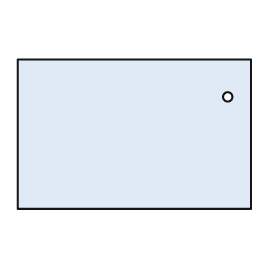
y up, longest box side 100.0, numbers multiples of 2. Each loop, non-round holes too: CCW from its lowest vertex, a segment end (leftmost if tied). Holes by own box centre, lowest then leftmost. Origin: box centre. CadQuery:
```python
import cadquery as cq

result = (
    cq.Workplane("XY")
    .moveTo(-50.0, -32.0)
    .lineTo(50.0, -32.0)
    .lineTo(50.0, 32.0)
    .lineTo(-50.0, 32.0)
    .close()
    .moveTo(40.0, 16.0)
    .circle(2.0)
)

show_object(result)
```